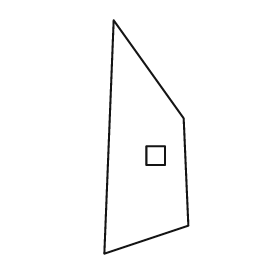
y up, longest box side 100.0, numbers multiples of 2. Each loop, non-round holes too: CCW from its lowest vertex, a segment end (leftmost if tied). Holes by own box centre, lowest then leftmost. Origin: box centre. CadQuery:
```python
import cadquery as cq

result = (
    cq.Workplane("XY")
    .moveTo(-18.0, -50.0)
    .lineTo(18.0, -38.0)
    .lineTo(16.0, 8.0)
    .lineTo(-14.0, 50.0)
    .close()
    .moveTo(0.0, -12.0)
    .lineTo(8.0, -12.0)
    .lineTo(8.0, -4.0)
    .lineTo(0.0, -4.0)
    .close()
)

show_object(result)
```